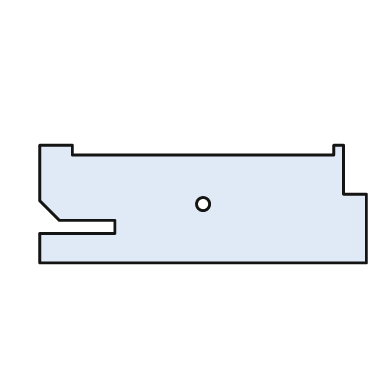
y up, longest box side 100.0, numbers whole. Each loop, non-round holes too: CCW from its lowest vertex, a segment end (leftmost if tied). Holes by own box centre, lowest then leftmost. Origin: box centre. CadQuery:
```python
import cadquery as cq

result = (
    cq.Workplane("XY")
    .moveTo(-50.0, -18.0)
    .lineTo(50.0, -18.0)
    .lineTo(50.0, 3.0)
    .lineTo(43.0, 3.0)
    .lineTo(43.0, 18.0)
    .lineTo(40.0, 18.0)
    .lineTo(40.0, 15.0)
    .lineTo(-40.0, 15.0)
    .lineTo(-40.0, 18.0)
    .lineTo(-50.0, 18.0)
    .lineTo(-50.0, 1.0)
    .lineTo(-44.0, -5.0)
    .lineTo(-27.0, -5.0)
    .lineTo(-27.0, -9.0)
    .lineTo(-50.0, -9.0)
    .close()
    .moveTo(0.0, 0.0)
    .circle(2.0)
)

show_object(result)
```